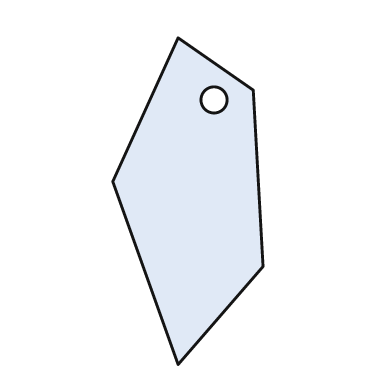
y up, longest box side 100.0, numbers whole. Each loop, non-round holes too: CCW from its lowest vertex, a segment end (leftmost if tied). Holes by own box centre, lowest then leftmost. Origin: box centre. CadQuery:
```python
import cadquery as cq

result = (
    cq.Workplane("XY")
    .moveTo(-3.0, -50.0)
    .lineTo(23.0, -20.0)
    .lineTo(20.0, 34.0)
    .lineTo(-3.0, 50.0)
    .lineTo(-23.0, 6.0)
    .close()
    .moveTo(8.0, 31.0)
    .circle(4.0)
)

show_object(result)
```